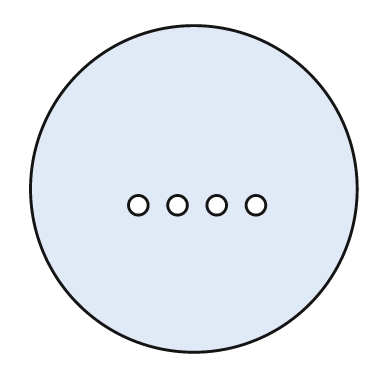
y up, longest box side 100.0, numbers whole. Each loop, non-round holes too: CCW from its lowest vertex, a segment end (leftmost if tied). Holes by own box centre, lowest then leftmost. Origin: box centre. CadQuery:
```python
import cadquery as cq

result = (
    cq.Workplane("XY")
    .moveTo(0.0, 0.0)
    .circle(50.0)
    .moveTo(-17.0, -5.0)
    .circle(3.0)
    .moveTo(-5.0, -5.0)
    .circle(3.0)
    .moveTo(7.0, -5.0)
    .circle(3.0)
    .moveTo(19.0, -5.0)
    .circle(3.0)
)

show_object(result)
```